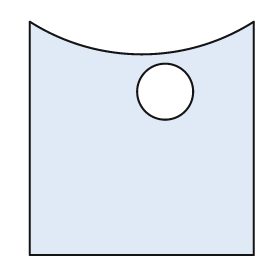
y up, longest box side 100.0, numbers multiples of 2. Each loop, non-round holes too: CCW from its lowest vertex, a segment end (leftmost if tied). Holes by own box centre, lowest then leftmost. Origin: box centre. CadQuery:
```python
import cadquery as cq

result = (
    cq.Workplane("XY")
    .moveTo(-48.0, -50.0)
    .lineTo(48.0, -50.0)
    .lineTo(48.0, 50.0)
    .threePointArc((0.0, 36.0), (-48.0, 50.0))
    .close()
    .moveTo(10.0, 20.0)
    .circle(12.0)
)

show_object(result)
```